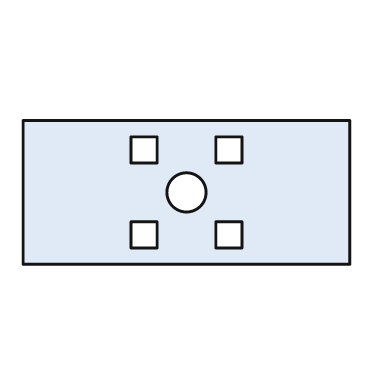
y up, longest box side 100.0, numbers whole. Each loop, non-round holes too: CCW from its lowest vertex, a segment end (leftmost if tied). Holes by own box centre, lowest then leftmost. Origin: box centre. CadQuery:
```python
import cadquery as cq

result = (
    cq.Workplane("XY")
    .moveTo(-50.0, -22.0)
    .lineTo(50.0, -22.0)
    .lineTo(50.0, 22.0)
    .lineTo(-50.0, 22.0)
    .close()
    .moveTo(-17.0, -17.0)
    .lineTo(-9.0, -17.0)
    .lineTo(-9.0, -9.0)
    .lineTo(-17.0, -9.0)
    .close()
    .moveTo(9.0, -17.0)
    .lineTo(17.0, -17.0)
    .lineTo(17.0, -9.0)
    .lineTo(9.0, -9.0)
    .close()
    .moveTo(0.0, 0.0)
    .circle(6.0)
    .moveTo(-17.0, 9.0)
    .lineTo(-9.0, 9.0)
    .lineTo(-9.0, 17.0)
    .lineTo(-17.0, 17.0)
    .close()
    .moveTo(9.0, 9.0)
    .lineTo(17.0, 9.0)
    .lineTo(17.0, 17.0)
    .lineTo(9.0, 17.0)
    .close()
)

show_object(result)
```